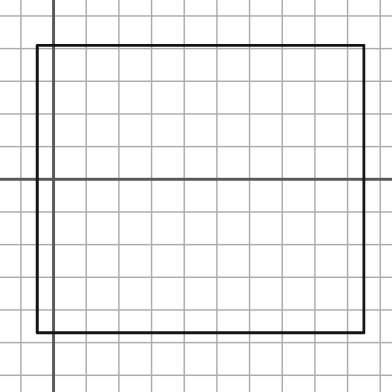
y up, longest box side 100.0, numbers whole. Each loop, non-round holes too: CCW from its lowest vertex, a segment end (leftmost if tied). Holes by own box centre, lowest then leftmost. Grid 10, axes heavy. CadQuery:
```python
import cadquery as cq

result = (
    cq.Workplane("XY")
    .moveTo(-5.0, -47.0)
    .lineTo(95.0, -47.0)
    .lineTo(95.0, 41.0)
    .lineTo(-5.0, 41.0)
    .close()
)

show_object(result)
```